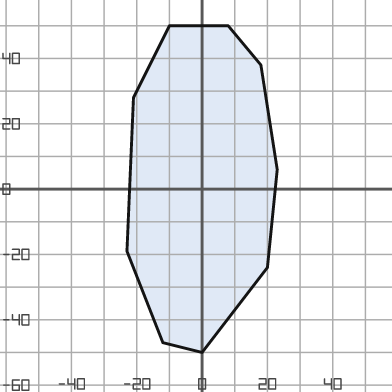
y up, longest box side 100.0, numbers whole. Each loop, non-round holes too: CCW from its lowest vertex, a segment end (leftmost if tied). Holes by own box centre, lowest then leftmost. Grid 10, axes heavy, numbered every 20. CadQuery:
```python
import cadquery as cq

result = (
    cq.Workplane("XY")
    .moveTo(0.0, -50.0)
    .lineTo(20.0, -24.0)
    .lineTo(23.0, 6.0)
    .lineTo(18.0, 38.0)
    .lineTo(8.0, 50.0)
    .lineTo(-10.0, 50.0)
    .lineTo(-21.0, 28.0)
    .lineTo(-23.0, -19.0)
    .lineTo(-12.0, -47.0)
    .close()
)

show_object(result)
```